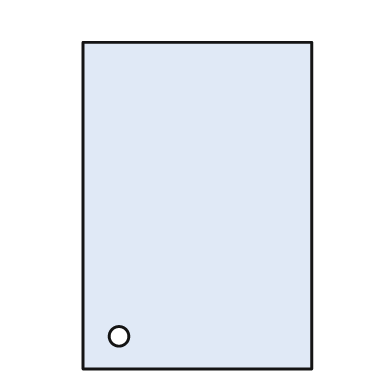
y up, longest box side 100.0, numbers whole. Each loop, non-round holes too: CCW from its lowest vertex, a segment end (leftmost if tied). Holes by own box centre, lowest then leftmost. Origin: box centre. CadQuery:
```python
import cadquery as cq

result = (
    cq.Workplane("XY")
    .moveTo(-35.0, -50.0)
    .lineTo(35.0, -50.0)
    .lineTo(35.0, 50.0)
    .lineTo(-35.0, 50.0)
    .close()
    .moveTo(-24.0, -40.0)
    .circle(3.0)
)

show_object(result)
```